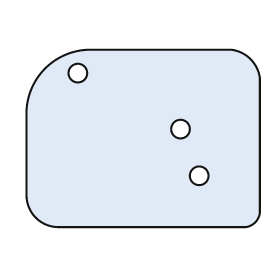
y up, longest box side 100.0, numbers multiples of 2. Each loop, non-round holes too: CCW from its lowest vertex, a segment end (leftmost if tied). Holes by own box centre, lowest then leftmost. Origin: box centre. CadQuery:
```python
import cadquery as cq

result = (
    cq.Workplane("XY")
    .moveTo(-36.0, -38.0)
    .lineTo(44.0, -38.0)
    .threePointArc((48.0, -36.0), (50.0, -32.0))
    .lineTo(50.0, 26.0)
    .threePointArc((46.0, 34.0), (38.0, 38.0))
    .lineTo(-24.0, 38.0)
    .threePointArc((-42.0, 30.0), (-50.0, 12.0))
    .lineTo(-50.0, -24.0)
    .threePointArc((-46.0, -34.0), (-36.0, -38.0))
    .close()
    .moveTo(24.0, -16.0)
    .circle(4.0)
    .moveTo(16.0, 4.0)
    .circle(4.0)
    .moveTo(-28.0, 28.0)
    .circle(4.0)
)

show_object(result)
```